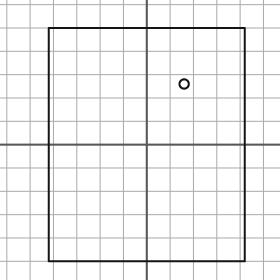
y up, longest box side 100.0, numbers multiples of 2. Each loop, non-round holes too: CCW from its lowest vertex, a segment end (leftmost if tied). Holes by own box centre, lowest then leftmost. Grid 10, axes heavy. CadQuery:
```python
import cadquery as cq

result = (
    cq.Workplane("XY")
    .moveTo(-42.0, -50.0)
    .lineTo(42.0, -50.0)
    .lineTo(42.0, 50.0)
    .lineTo(-42.0, 50.0)
    .close()
    .moveTo(16.0, 26.0)
    .circle(2.0)
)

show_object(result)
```